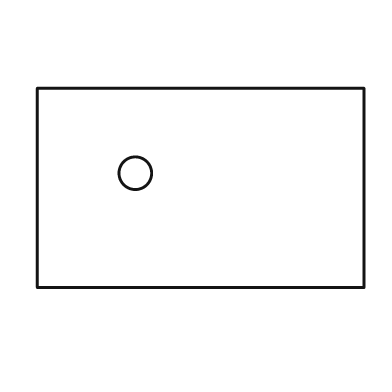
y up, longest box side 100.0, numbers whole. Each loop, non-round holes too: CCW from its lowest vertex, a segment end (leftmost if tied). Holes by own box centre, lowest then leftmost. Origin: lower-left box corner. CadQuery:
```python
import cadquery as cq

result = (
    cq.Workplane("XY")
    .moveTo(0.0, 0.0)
    .lineTo(100.0, 0.0)
    .lineTo(100.0, 61.0)
    .lineTo(0.0, 61.0)
    .close()
    .moveTo(30.0, 35.0)
    .circle(5.0)
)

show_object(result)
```